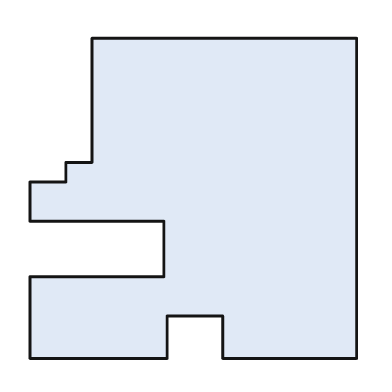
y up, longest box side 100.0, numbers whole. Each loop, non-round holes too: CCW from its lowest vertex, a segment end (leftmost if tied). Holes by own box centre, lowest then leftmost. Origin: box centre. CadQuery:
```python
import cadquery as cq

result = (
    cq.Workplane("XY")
    .moveTo(-50.0, -49.0)
    .lineTo(-8.0, -49.0)
    .lineTo(-8.0, -36.0)
    .lineTo(9.0, -36.0)
    .lineTo(9.0, -49.0)
    .lineTo(50.0, -49.0)
    .lineTo(50.0, 49.0)
    .lineTo(-31.0, 49.0)
    .lineTo(-31.0, 11.0)
    .lineTo(-39.0, 11.0)
    .lineTo(-39.0, 5.0)
    .lineTo(-50.0, 5.0)
    .lineTo(-50.0, -7.0)
    .lineTo(-9.0, -7.0)
    .lineTo(-9.0, -24.0)
    .lineTo(-50.0, -24.0)
    .close()
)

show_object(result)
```